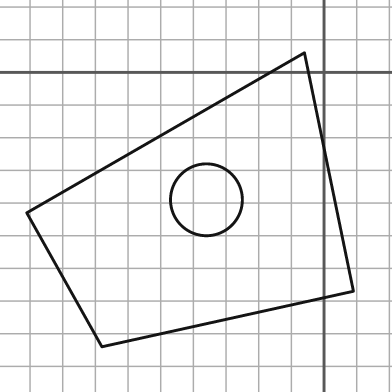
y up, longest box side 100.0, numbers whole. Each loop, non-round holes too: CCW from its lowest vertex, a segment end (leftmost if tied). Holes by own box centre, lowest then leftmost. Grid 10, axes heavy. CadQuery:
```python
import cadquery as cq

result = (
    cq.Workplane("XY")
    .moveTo(-68.0, -84.0)
    .lineTo(9.0, -67.0)
    .lineTo(-6.0, 6.0)
    .lineTo(-91.0, -43.0)
    .close()
    .moveTo(-36.0, -39.0)
    .circle(11.0)
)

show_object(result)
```